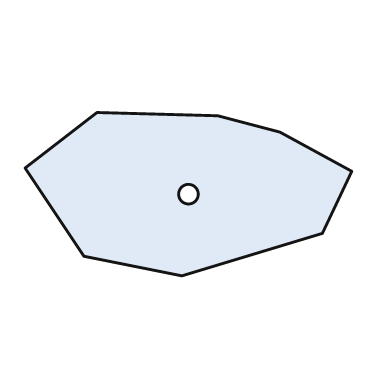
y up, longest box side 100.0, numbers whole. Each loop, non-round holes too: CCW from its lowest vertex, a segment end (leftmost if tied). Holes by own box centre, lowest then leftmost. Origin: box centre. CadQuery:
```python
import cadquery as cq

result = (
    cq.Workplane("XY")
    .moveTo(-2.0, -25.0)
    .lineTo(41.0, -12.0)
    .lineTo(50.0, 7.0)
    .lineTo(28.0, 19.0)
    .lineTo(9.0, 24.0)
    .lineTo(-28.0, 25.0)
    .lineTo(-50.0, 8.0)
    .lineTo(-32.0, -19.0)
    .close()
    .moveTo(0.0, 0.0)
    .circle(3.0)
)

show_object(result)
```